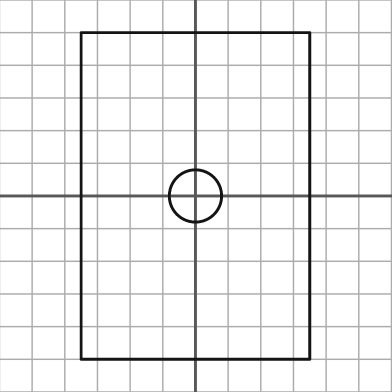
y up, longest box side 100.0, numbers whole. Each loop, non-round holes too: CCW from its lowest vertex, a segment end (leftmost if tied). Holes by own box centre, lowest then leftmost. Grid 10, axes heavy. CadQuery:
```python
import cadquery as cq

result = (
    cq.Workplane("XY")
    .moveTo(-35.0, -50.0)
    .lineTo(35.0, -50.0)
    .lineTo(35.0, 50.0)
    .lineTo(-35.0, 50.0)
    .close()
    .moveTo(0.0, 0.0)
    .circle(8.0)
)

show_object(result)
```